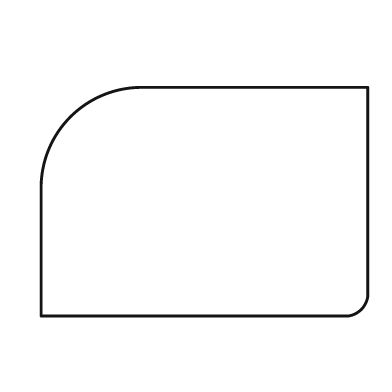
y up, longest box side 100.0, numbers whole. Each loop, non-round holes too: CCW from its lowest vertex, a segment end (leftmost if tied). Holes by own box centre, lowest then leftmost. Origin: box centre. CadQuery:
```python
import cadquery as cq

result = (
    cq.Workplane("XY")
    .moveTo(-50.0, -35.0)
    .lineTo(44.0, -35.0)
    .threePointArc((48.0, -33.0), (50.0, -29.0))
    .lineTo(50.0, 35.0)
    .lineTo(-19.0, 35.0)
    .threePointArc((-41.0, 26.0), (-50.0, 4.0))
    .close()
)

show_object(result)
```